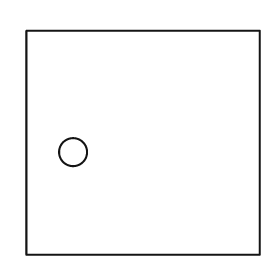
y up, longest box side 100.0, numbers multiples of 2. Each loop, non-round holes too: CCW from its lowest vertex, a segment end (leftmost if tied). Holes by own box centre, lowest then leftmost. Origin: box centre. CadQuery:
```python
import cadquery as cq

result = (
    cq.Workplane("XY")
    .moveTo(-50.0, -48.0)
    .lineTo(50.0, -48.0)
    .lineTo(50.0, 48.0)
    .lineTo(-50.0, 48.0)
    .close()
    .moveTo(-30.0, -4.0)
    .circle(6.0)
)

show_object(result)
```